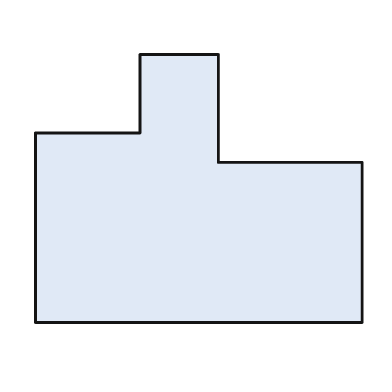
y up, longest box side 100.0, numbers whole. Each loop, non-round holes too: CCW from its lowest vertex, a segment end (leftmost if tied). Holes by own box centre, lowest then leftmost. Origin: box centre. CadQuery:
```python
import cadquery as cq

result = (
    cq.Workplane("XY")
    .moveTo(-50.0, -41.0)
    .lineTo(50.0, -41.0)
    .lineTo(50.0, 8.0)
    .lineTo(6.0, 8.0)
    .lineTo(6.0, 41.0)
    .lineTo(-18.0, 41.0)
    .lineTo(-18.0, 17.0)
    .lineTo(-50.0, 17.0)
    .close()
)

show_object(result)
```